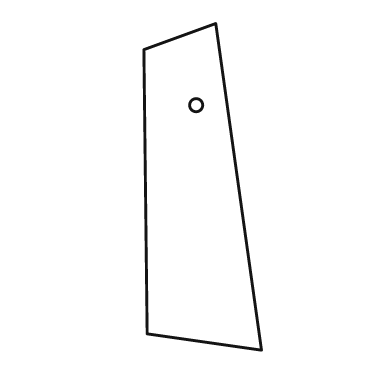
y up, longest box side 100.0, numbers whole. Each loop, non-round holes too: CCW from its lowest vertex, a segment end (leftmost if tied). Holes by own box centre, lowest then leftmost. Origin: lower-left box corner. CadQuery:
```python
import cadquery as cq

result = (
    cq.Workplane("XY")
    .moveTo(36.0, 0.0)
    .lineTo(22.0, 100.0)
    .lineTo(0.0, 92.0)
    .lineTo(1.0, 5.0)
    .close()
    .moveTo(16.0, 75.0)
    .circle(2.0)
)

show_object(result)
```